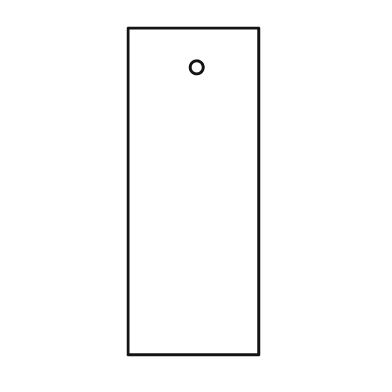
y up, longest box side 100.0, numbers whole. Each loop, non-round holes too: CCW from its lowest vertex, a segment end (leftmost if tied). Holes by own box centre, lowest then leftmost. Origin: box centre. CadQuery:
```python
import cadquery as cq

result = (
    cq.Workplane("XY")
    .moveTo(-20.0, -50.0)
    .lineTo(20.0, -50.0)
    .lineTo(20.0, 50.0)
    .lineTo(-20.0, 50.0)
    .close()
    .moveTo(1.0, 38.0)
    .circle(2.0)
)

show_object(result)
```